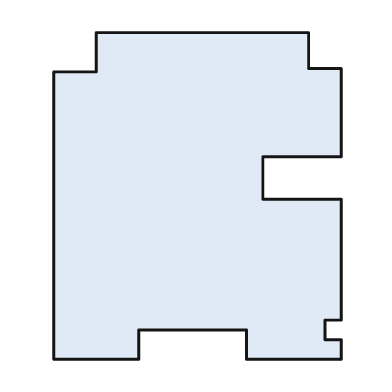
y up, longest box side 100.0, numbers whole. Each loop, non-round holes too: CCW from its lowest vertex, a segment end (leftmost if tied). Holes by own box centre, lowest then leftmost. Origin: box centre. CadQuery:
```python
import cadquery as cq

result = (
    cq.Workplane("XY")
    .moveTo(-44.0, -50.0)
    .lineTo(-18.0, -50.0)
    .lineTo(-18.0, -41.0)
    .lineTo(15.0, -41.0)
    .lineTo(15.0, -50.0)
    .lineTo(44.0, -50.0)
    .lineTo(44.0, -44.0)
    .lineTo(39.0, -44.0)
    .lineTo(39.0, -38.0)
    .lineTo(44.0, -38.0)
    .lineTo(44.0, -1.0)
    .lineTo(20.0, -1.0)
    .lineTo(20.0, 12.0)
    .lineTo(44.0, 12.0)
    .lineTo(44.0, 39.0)
    .lineTo(34.0, 39.0)
    .lineTo(34.0, 50.0)
    .lineTo(-31.0, 50.0)
    .lineTo(-31.0, 38.0)
    .lineTo(-44.0, 38.0)
    .close()
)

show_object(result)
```